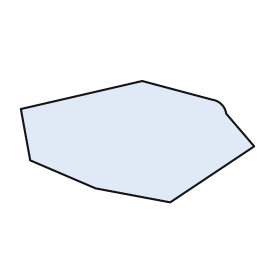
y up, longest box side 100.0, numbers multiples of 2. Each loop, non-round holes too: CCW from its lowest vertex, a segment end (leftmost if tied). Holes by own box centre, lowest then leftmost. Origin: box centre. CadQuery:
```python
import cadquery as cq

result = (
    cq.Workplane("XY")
    .moveTo(14.0, -26.0)
    .lineTo(50.0, -2.0)
    .lineTo(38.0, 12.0)
    .threePointArc((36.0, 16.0), (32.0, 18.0))
    .lineTo(2.0, 26.0)
    .lineTo(-50.0, 14.0)
    .lineTo(-46.0, -8.0)
    .lineTo(-18.0, -20.0)
    .close()
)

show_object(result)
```